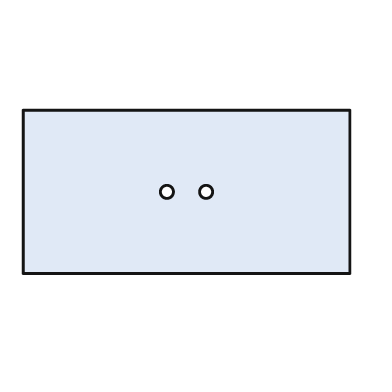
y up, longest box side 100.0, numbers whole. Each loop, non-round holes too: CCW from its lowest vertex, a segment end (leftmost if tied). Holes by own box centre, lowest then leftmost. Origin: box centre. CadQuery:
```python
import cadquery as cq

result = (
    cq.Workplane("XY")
    .moveTo(-50.0, -25.0)
    .lineTo(50.0, -25.0)
    .lineTo(50.0, 25.0)
    .lineTo(-50.0, 25.0)
    .close()
    .moveTo(-6.0, 0.0)
    .circle(2.0)
    .moveTo(6.0, 0.0)
    .circle(2.0)
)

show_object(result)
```